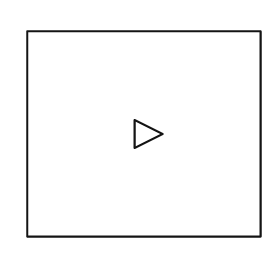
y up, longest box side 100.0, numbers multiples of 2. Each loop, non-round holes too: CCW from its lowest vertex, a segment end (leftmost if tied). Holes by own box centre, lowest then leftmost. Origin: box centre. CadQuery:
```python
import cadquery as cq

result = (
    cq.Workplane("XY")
    .moveTo(-50.0, -44.0)
    .lineTo(50.0, -44.0)
    .lineTo(50.0, 44.0)
    .lineTo(-50.0, 44.0)
    .close()
    .moveTo(-4.0, -6.0)
    .lineTo(8.0, 0.0)
    .lineTo(-4.0, 6.0)
    .close()
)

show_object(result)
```